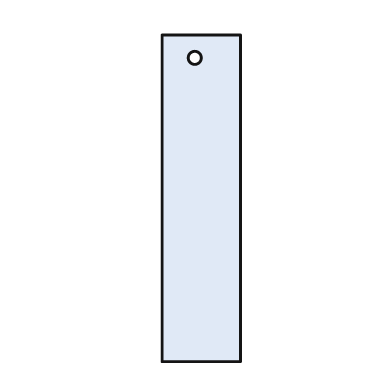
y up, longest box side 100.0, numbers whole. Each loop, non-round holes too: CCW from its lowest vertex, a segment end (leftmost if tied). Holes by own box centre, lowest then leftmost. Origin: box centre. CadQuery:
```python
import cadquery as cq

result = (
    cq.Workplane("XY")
    .moveTo(-12.0, -50.0)
    .lineTo(12.0, -50.0)
    .lineTo(12.0, 50.0)
    .lineTo(-12.0, 50.0)
    .close()
    .moveTo(-2.0, 43.0)
    .circle(2.0)
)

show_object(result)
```